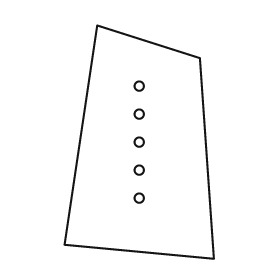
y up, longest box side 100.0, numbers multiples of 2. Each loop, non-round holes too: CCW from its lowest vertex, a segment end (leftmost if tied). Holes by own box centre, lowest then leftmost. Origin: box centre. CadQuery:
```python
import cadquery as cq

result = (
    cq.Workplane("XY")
    .moveTo(32.0, -50.0)
    .lineTo(26.0, 36.0)
    .lineTo(-18.0, 50.0)
    .lineTo(-32.0, -44.0)
    .close()
    .moveTo(0.0, -24.0)
    .circle(2.0)
    .moveTo(0.0, -12.0)
    .circle(2.0)
    .moveTo(0.0, 0.0)
    .circle(2.0)
    .moveTo(0.0, 12.0)
    .circle(2.0)
    .moveTo(0.0, 24.0)
    .circle(2.0)
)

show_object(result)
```